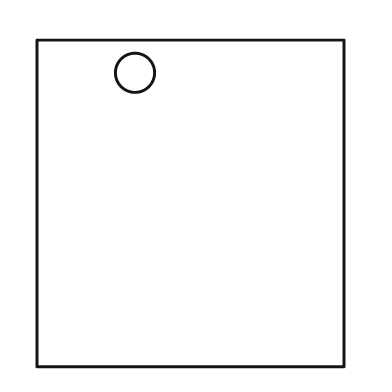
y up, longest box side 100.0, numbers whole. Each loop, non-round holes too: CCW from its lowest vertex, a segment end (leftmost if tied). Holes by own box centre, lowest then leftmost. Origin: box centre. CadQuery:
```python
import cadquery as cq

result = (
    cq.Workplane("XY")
    .moveTo(-47.0, -50.0)
    .lineTo(47.0, -50.0)
    .lineTo(47.0, 50.0)
    .lineTo(-47.0, 50.0)
    .close()
    .moveTo(-17.0, 40.0)
    .circle(6.0)
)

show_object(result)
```